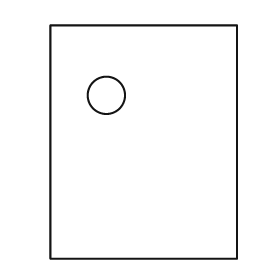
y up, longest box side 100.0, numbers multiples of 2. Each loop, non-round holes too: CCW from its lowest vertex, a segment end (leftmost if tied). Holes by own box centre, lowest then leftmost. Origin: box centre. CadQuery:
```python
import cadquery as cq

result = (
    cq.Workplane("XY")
    .moveTo(-40.0, -50.0)
    .lineTo(40.0, -50.0)
    .lineTo(40.0, 50.0)
    .lineTo(-40.0, 50.0)
    .close()
    .moveTo(-16.0, 20.0)
    .circle(8.0)
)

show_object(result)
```